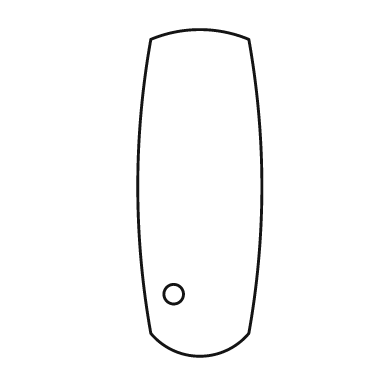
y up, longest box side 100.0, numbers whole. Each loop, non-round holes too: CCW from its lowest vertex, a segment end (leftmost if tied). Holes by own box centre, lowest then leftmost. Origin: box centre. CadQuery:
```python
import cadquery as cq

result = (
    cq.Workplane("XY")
    .moveTo(-15.0, -43.0)
    .threePointArc((0.0, -50.0), (15.0, -43.0))
    .threePointArc((19.0, 2.0), (15.0, 47.0))
    .threePointArc((0.0, 50.0), (-15.0, 47.0))
    .threePointArc((-19.0, 2.0), (-15.0, -43.0))
    .close()
    .moveTo(-8.0, -31.0)
    .circle(3.0)
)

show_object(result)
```